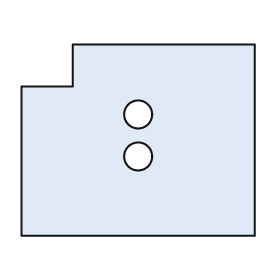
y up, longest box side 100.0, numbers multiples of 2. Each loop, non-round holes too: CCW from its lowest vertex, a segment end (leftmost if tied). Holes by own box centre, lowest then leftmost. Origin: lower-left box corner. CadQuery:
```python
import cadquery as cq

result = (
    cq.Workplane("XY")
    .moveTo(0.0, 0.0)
    .lineTo(100.0, 0.0)
    .lineTo(100.0, 82.0)
    .lineTo(22.0, 82.0)
    .lineTo(22.0, 64.0)
    .lineTo(0.0, 64.0)
    .close()
    .moveTo(50.0, 34.0)
    .circle(6.0)
    .moveTo(50.0, 52.0)
    .circle(6.0)
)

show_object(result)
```